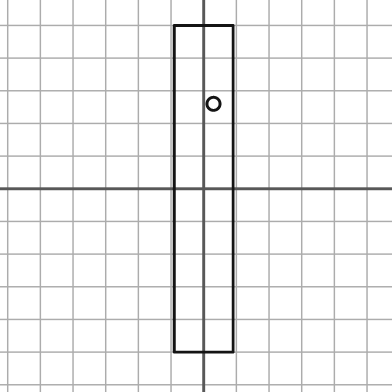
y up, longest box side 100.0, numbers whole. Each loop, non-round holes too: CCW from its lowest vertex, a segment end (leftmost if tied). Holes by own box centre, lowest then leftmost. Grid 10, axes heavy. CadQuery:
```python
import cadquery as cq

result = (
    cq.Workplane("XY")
    .moveTo(-9.0, -50.0)
    .lineTo(9.0, -50.0)
    .lineTo(9.0, 50.0)
    .lineTo(-9.0, 50.0)
    .close()
    .moveTo(3.0, 26.0)
    .circle(2.0)
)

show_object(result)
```